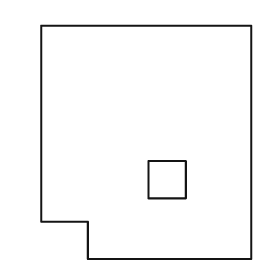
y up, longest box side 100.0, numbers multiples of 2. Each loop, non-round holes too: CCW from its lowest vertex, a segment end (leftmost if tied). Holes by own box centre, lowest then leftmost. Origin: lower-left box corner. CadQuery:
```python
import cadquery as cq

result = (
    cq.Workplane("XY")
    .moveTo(20.0, 0.0)
    .lineTo(90.0, 0.0)
    .lineTo(90.0, 100.0)
    .lineTo(0.0, 100.0)
    .lineTo(0.0, 16.0)
    .lineTo(20.0, 16.0)
    .close()
    .moveTo(46.0, 26.0)
    .lineTo(62.0, 26.0)
    .lineTo(62.0, 42.0)
    .lineTo(46.0, 42.0)
    .close()
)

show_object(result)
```